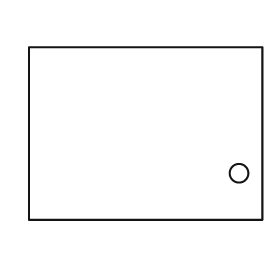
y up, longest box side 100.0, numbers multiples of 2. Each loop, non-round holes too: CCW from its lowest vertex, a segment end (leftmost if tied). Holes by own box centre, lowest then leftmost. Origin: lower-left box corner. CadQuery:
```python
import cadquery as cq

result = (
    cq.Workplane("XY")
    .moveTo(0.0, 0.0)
    .lineTo(100.0, 0.0)
    .lineTo(100.0, 74.0)
    .lineTo(0.0, 74.0)
    .close()
    .moveTo(90.0, 20.0)
    .circle(4.0)
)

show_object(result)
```